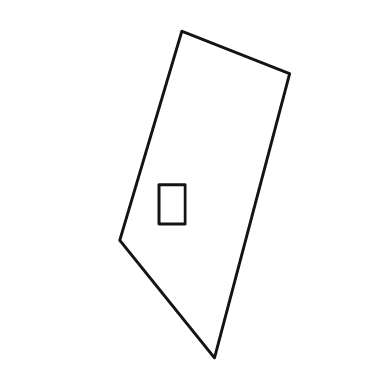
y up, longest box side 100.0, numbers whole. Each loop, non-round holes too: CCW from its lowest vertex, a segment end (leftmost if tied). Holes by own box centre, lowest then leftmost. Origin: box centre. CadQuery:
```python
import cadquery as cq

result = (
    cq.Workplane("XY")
    .moveTo(3.0, -50.0)
    .lineTo(26.0, 37.0)
    .lineTo(-7.0, 50.0)
    .lineTo(-26.0, -14.0)
    .close()
    .moveTo(-14.0, -9.0)
    .lineTo(-6.0, -9.0)
    .lineTo(-6.0, 3.0)
    .lineTo(-14.0, 3.0)
    .close()
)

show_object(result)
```